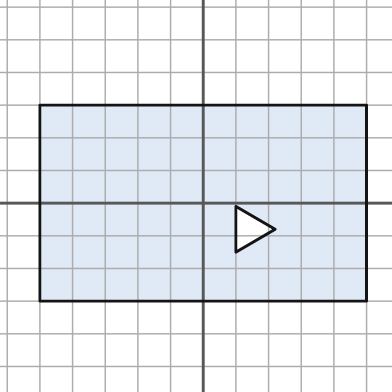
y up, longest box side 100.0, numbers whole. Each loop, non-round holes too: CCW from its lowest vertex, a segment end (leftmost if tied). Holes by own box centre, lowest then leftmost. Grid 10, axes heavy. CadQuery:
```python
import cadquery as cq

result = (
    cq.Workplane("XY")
    .moveTo(-50.0, -30.0)
    .lineTo(50.0, -30.0)
    .lineTo(50.0, 30.0)
    .lineTo(-50.0, 30.0)
    .close()
    .moveTo(10.0, -15.0)
    .lineTo(22.0, -8.0)
    .lineTo(10.0, -1.0)
    .close()
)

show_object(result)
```